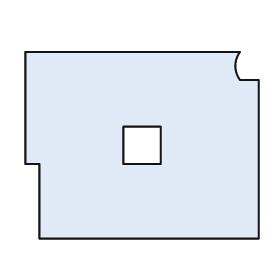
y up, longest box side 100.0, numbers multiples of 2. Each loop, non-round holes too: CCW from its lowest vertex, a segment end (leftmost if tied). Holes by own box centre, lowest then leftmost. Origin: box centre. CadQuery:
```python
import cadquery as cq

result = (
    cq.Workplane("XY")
    .moveTo(-44.0, -40.0)
    .lineTo(50.0, -40.0)
    .lineTo(50.0, 28.0)
    .lineTo(42.0, 28.0)
    .threePointArc((40.0, 34.0), (42.0, 40.0))
    .lineTo(-50.0, 40.0)
    .lineTo(-50.0, -8.0)
    .lineTo(-44.0, -8.0)
    .close()
    .moveTo(-8.0, -8.0)
    .lineTo(8.0, -8.0)
    .lineTo(8.0, 8.0)
    .lineTo(-8.0, 8.0)
    .close()
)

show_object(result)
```